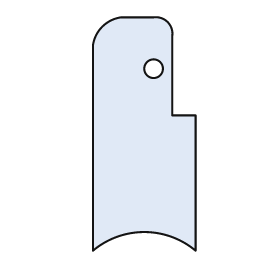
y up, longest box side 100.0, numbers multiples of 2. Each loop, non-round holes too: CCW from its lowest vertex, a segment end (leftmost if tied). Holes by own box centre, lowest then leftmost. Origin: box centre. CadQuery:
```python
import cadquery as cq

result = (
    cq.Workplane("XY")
    .moveTo(-22.0, -50.0)
    .threePointArc((0.0, -42.0), (22.0, -50.0))
    .lineTo(22.0, 8.0)
    .lineTo(12.0, 8.0)
    .lineTo(12.0, 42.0)
    .threePointArc((10.0, 48.0), (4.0, 50.0))
    .lineTo(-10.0, 50.0)
    .threePointArc((-18.0, 46.0), (-22.0, 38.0))
    .close()
    .moveTo(4.0, 28.0)
    .circle(4.0)
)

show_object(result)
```